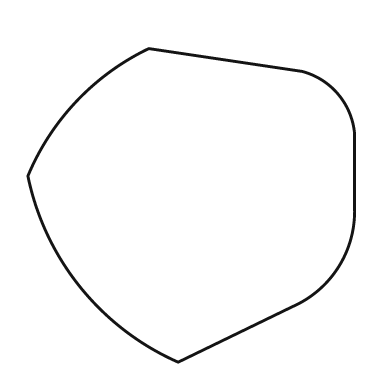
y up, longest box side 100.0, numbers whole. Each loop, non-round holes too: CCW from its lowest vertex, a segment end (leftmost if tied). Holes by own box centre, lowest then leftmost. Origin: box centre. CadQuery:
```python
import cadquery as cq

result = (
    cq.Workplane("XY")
    .moveTo(-4.0, -48.0)
    .lineTo(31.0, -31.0)
    .threePointArc((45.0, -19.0), (50.0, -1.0))
    .lineTo(50.0, 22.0)
    .threePointArc((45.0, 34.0), (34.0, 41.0))
    .lineTo(-13.0, 48.0)
    .threePointArc((-35.0, 32.0), (-50.0, 9.0))
    .threePointArc((-34.0, -25.0), (-4.0, -48.0))
    .close()
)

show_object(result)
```